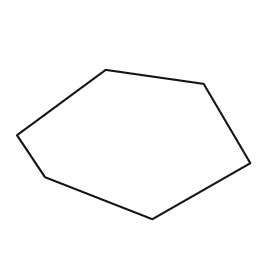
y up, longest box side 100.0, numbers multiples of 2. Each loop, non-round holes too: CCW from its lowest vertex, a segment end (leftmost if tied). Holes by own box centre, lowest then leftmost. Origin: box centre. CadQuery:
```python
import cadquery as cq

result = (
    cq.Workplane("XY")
    .moveTo(8.0, -32.0)
    .lineTo(50.0, -8.0)
    .lineTo(30.0, 26.0)
    .lineTo(-12.0, 32.0)
    .lineTo(-50.0, 4.0)
    .lineTo(-38.0, -14.0)
    .close()
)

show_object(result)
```